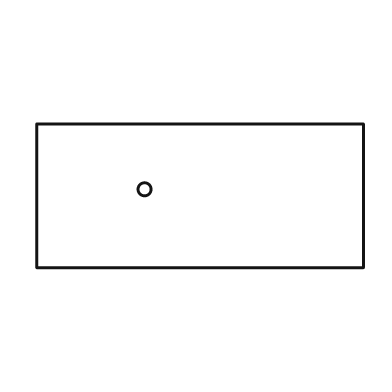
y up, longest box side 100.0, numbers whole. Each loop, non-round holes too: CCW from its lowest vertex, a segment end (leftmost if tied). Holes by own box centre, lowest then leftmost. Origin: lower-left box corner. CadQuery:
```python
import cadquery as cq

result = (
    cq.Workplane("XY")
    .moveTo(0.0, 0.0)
    .lineTo(100.0, 0.0)
    .lineTo(100.0, 44.0)
    .lineTo(0.0, 44.0)
    .close()
    .moveTo(33.0, 24.0)
    .circle(2.0)
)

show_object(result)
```